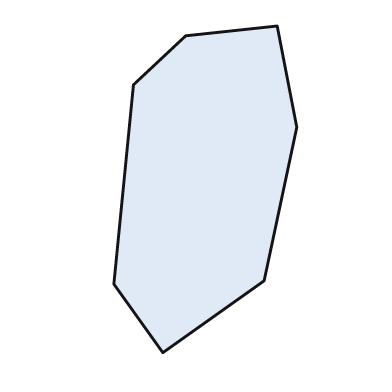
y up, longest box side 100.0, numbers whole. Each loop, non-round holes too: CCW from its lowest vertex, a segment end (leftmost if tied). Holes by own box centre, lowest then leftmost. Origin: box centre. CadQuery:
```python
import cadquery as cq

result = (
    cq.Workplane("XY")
    .moveTo(-13.0, -50.0)
    .lineTo(18.0, -28.0)
    .lineTo(28.0, 19.0)
    .lineTo(22.0, 50.0)
    .lineTo(-6.0, 47.0)
    .lineTo(-22.0, 32.0)
    .lineTo(-28.0, -29.0)
    .close()
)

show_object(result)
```